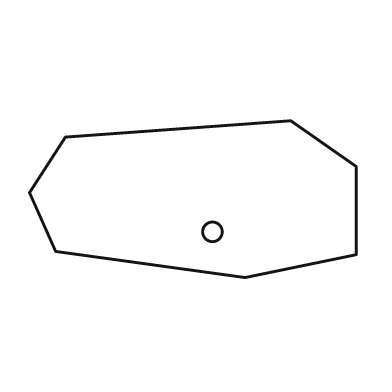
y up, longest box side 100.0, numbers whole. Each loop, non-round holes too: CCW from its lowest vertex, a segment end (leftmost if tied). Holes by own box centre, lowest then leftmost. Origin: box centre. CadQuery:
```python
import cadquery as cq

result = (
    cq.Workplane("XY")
    .moveTo(16.0, -24.0)
    .lineTo(50.0, -17.0)
    .lineTo(50.0, 10.0)
    .lineTo(30.0, 24.0)
    .lineTo(-39.0, 19.0)
    .lineTo(-50.0, 2.0)
    .lineTo(-42.0, -16.0)
    .close()
    .moveTo(6.0, -10.0)
    .circle(3.0)
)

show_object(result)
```